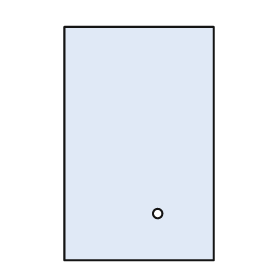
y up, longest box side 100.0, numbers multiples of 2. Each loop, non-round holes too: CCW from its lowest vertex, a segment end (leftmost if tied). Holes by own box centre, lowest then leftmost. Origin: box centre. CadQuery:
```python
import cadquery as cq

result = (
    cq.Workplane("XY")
    .moveTo(-32.0, -50.0)
    .lineTo(32.0, -50.0)
    .lineTo(32.0, 50.0)
    .lineTo(-32.0, 50.0)
    .close()
    .moveTo(8.0, -30.0)
    .circle(2.0)
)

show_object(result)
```